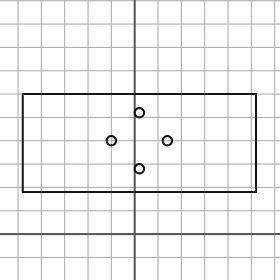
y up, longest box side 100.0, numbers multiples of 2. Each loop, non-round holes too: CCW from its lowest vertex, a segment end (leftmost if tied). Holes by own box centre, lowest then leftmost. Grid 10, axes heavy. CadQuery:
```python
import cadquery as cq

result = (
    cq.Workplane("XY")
    .moveTo(-48.0, 18.0)
    .lineTo(52.0, 18.0)
    .lineTo(52.0, 60.0)
    .lineTo(-48.0, 60.0)
    .close()
    .moveTo(2.0, 28.0)
    .circle(2.0)
    .moveTo(-10.0, 40.0)
    .circle(2.0)
    .moveTo(14.0, 40.0)
    .circle(2.0)
    .moveTo(2.0, 52.0)
    .circle(2.0)
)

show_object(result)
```